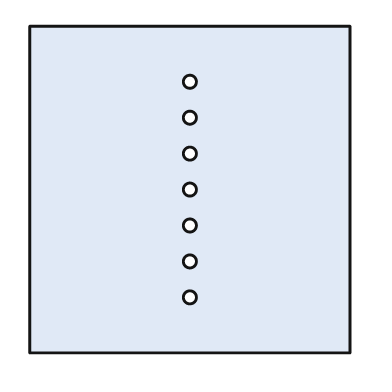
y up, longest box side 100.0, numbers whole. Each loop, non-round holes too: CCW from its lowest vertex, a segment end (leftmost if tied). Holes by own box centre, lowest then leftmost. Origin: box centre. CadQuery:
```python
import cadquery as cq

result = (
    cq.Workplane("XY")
    .moveTo(-49.0, -50.0)
    .lineTo(49.0, -50.0)
    .lineTo(49.0, 50.0)
    .lineTo(-49.0, 50.0)
    .close()
    .moveTo(0.0, -33.0)
    .circle(2.0)
    .moveTo(0.0, -22.0)
    .circle(2.0)
    .moveTo(0.0, -11.0)
    .circle(2.0)
    .moveTo(0.0, 0.0)
    .circle(2.0)
    .moveTo(0.0, 11.0)
    .circle(2.0)
    .moveTo(0.0, 22.0)
    .circle(2.0)
    .moveTo(0.0, 33.0)
    .circle(2.0)
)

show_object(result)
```